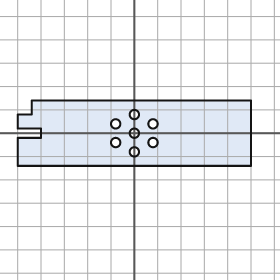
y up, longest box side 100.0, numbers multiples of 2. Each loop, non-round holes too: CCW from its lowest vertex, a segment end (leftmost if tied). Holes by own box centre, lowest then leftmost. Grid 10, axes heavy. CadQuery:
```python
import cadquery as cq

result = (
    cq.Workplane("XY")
    .moveTo(-50.0, -14.0)
    .lineTo(50.0, -14.0)
    .lineTo(50.0, 14.0)
    .lineTo(-44.0, 14.0)
    .lineTo(-44.0, 8.0)
    .lineTo(-50.0, 8.0)
    .lineTo(-50.0, 2.0)
    .lineTo(-40.0, 2.0)
    .lineTo(-40.0, -2.0)
    .lineTo(-50.0, -2.0)
    .close()
    .moveTo(0.0, -8.0)
    .circle(2.0)
    .moveTo(-8.0, -4.0)
    .circle(2.0)
    .moveTo(8.0, -4.0)
    .circle(2.0)
    .moveTo(0.0, 0.0)
    .circle(2.0)
    .moveTo(-8.0, 4.0)
    .circle(2.0)
    .moveTo(8.0, 4.0)
    .circle(2.0)
    .moveTo(0.0, 8.0)
    .circle(2.0)
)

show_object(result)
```